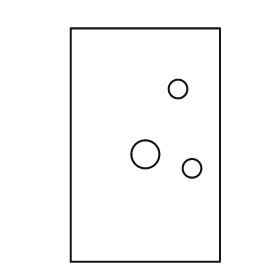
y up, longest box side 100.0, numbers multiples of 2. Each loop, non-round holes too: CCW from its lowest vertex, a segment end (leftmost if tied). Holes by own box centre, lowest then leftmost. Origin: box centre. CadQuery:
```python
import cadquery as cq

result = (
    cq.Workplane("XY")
    .moveTo(-32.0, -50.0)
    .lineTo(32.0, -50.0)
    .lineTo(32.0, 50.0)
    .lineTo(-32.0, 50.0)
    .close()
    .moveTo(20.0, -10.0)
    .circle(4.0)
    .moveTo(0.0, -4.0)
    .circle(6.0)
    .moveTo(14.0, 24.0)
    .circle(4.0)
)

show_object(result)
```